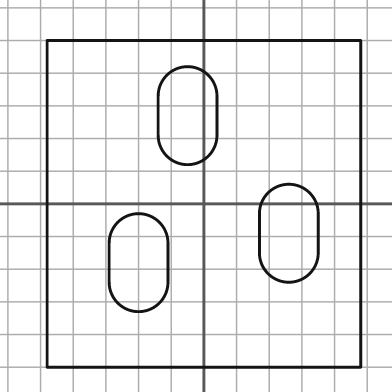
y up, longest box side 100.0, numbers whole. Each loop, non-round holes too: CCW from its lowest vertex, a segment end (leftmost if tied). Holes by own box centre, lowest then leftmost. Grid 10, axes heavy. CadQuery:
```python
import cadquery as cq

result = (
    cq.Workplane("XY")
    .moveTo(-48.0, -50.0)
    .lineTo(48.0, -50.0)
    .lineTo(48.0, 50.0)
    .lineTo(-48.0, 50.0)
    .close()
    .moveTo(-29.0, -24.0)
    .threePointArc((-20.0, -33.0), (-11.0, -24.0))
    .lineTo(-11.0, -12.0)
    .threePointArc((-20.0, -3.0), (-29.0, -12.0))
    .close()
    .moveTo(17.0, -15.0)
    .threePointArc((26.0, -24.0), (35.0, -15.0))
    .lineTo(35.0, -3.0)
    .threePointArc((26.0, 6.0), (17.0, -3.0))
    .close()
    .moveTo(-14.0, 21.0)
    .threePointArc((-5.0, 12.0), (4.0, 21.0))
    .lineTo(4.0, 33.0)
    .threePointArc((-5.0, 42.0), (-14.0, 33.0))
    .close()
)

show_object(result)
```